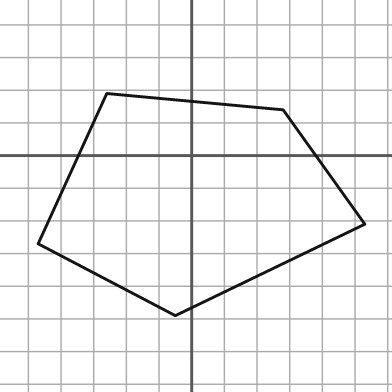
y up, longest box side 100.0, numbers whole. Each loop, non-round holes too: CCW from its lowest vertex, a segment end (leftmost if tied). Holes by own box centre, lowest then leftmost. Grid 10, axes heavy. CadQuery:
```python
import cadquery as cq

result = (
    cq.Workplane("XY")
    .moveTo(-5.0, -49.0)
    .lineTo(53.0, -21.0)
    .lineTo(28.0, 14.0)
    .lineTo(-26.0, 19.0)
    .lineTo(-47.0, -27.0)
    .close()
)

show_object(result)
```